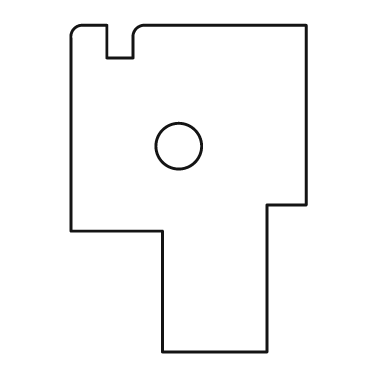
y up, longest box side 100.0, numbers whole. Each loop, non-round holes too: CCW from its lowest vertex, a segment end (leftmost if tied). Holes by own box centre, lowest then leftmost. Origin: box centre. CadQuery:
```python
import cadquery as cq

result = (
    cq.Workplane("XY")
    .moveTo(-8.0, -50.0)
    .lineTo(24.0, -50.0)
    .lineTo(24.0, -5.0)
    .lineTo(36.0, -5.0)
    .lineTo(36.0, 50.0)
    .lineTo(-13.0, 50.0)
    .threePointArc((-16.0, 49.0), (-17.0, 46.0))
    .lineTo(-17.0, 40.0)
    .lineTo(-25.0, 40.0)
    .lineTo(-25.0, 50.0)
    .lineTo(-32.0, 50.0)
    .threePointArc((-35.0, 49.0), (-36.0, 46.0))
    .lineTo(-36.0, -13.0)
    .lineTo(-8.0, -13.0)
    .close()
    .moveTo(-3.0, 13.0)
    .circle(7.0)
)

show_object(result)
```